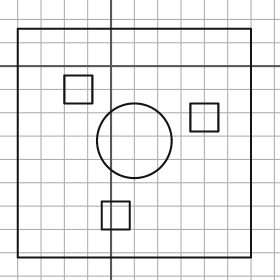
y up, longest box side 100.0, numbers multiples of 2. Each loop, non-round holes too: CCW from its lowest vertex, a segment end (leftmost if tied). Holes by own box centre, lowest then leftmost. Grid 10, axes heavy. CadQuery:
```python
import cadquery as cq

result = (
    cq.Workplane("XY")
    .moveTo(-40.0, -82.0)
    .lineTo(60.0, -82.0)
    .lineTo(60.0, 16.0)
    .lineTo(-40.0, 16.0)
    .close()
    .moveTo(-4.0, -70.0)
    .lineTo(8.0, -70.0)
    .lineTo(8.0, -58.0)
    .lineTo(-4.0, -58.0)
    .close()
    .moveTo(10.0, -32.0)
    .circle(16.0)
    .moveTo(34.0, -28.0)
    .lineTo(46.0, -28.0)
    .lineTo(46.0, -16.0)
    .lineTo(34.0, -16.0)
    .close()
    .moveTo(-20.0, -16.0)
    .lineTo(-8.0, -16.0)
    .lineTo(-8.0, -4.0)
    .lineTo(-20.0, -4.0)
    .close()
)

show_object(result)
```